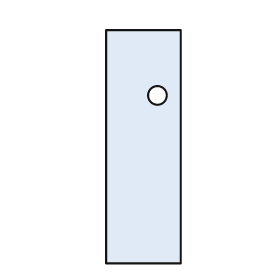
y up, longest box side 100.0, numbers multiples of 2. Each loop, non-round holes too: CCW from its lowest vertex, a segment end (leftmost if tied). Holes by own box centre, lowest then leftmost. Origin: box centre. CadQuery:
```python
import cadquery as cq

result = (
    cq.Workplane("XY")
    .moveTo(-16.0, -50.0)
    .lineTo(16.0, -50.0)
    .lineTo(16.0, 50.0)
    .lineTo(-16.0, 50.0)
    .close()
    .moveTo(6.0, 22.0)
    .circle(4.0)
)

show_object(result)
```